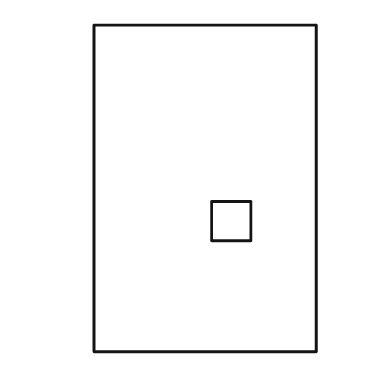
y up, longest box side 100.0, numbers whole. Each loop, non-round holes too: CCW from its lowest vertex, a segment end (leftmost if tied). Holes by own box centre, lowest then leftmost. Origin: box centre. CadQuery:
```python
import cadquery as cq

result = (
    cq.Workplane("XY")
    .moveTo(-34.0, -50.0)
    .lineTo(34.0, -50.0)
    .lineTo(34.0, 50.0)
    .lineTo(-34.0, 50.0)
    .close()
    .moveTo(2.0, -16.0)
    .lineTo(14.0, -16.0)
    .lineTo(14.0, -4.0)
    .lineTo(2.0, -4.0)
    .close()
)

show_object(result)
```